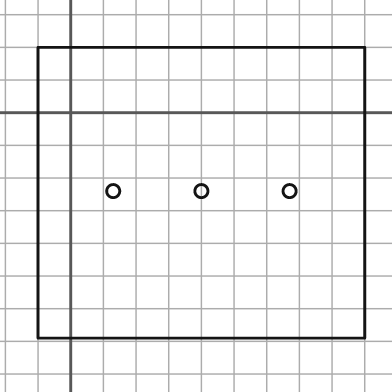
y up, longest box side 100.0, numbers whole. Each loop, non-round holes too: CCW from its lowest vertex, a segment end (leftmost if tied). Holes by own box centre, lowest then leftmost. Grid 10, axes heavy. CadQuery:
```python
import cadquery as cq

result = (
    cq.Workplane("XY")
    .moveTo(-10.0, -69.0)
    .lineTo(90.0, -69.0)
    .lineTo(90.0, 20.0)
    .lineTo(-10.0, 20.0)
    .close()
    .moveTo(13.0, -24.0)
    .circle(2.0)
    .moveTo(40.0, -24.0)
    .circle(2.0)
    .moveTo(67.0, -24.0)
    .circle(2.0)
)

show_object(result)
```